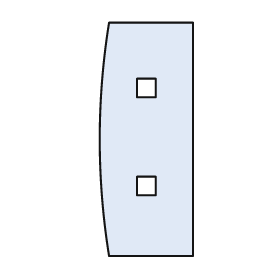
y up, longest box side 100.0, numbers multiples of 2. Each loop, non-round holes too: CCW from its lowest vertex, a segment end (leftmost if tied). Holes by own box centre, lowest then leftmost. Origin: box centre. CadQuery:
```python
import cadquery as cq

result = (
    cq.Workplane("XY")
    .moveTo(-16.0, -50.0)
    .lineTo(20.0, -50.0)
    .lineTo(20.0, 50.0)
    .lineTo(-16.0, 50.0)
    .threePointArc((-20.0, 0.0), (-16.0, -50.0))
    .close()
    .moveTo(-4.0, -24.0)
    .lineTo(4.0, -24.0)
    .lineTo(4.0, -16.0)
    .lineTo(-4.0, -16.0)
    .close()
    .moveTo(-4.0, 18.0)
    .lineTo(4.0, 18.0)
    .lineTo(4.0, 26.0)
    .lineTo(-4.0, 26.0)
    .close()
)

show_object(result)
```